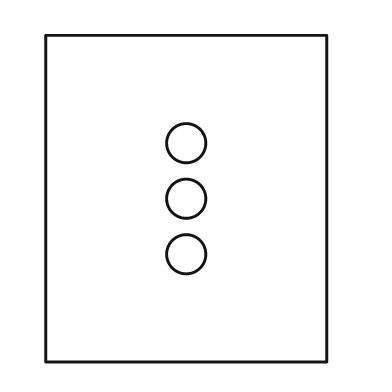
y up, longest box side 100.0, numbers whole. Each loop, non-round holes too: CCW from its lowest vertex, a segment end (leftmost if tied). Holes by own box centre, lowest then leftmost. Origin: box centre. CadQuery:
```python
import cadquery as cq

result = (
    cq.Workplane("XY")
    .moveTo(-43.0, -50.0)
    .lineTo(43.0, -50.0)
    .lineTo(43.0, 50.0)
    .lineTo(-43.0, 50.0)
    .close()
    .moveTo(0.0, -17.0)
    .circle(6.0)
    .moveTo(0.0, 0.0)
    .circle(6.0)
    .moveTo(0.0, 17.0)
    .circle(6.0)
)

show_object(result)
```